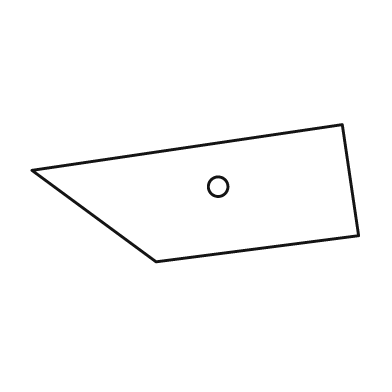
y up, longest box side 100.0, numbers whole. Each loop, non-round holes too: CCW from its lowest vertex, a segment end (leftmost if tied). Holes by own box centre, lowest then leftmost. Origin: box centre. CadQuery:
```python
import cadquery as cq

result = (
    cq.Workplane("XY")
    .moveTo(-12.0, -21.0)
    .lineTo(50.0, -13.0)
    .lineTo(45.0, 21.0)
    .lineTo(-50.0, 7.0)
    .close()
    .moveTo(7.0, 2.0)
    .circle(3.0)
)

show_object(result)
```